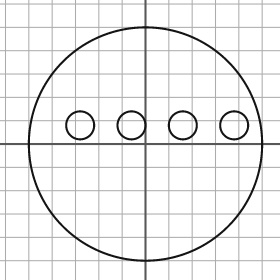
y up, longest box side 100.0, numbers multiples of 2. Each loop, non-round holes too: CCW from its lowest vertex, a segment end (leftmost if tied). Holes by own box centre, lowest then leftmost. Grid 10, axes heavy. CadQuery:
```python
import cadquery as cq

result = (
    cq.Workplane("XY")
    .moveTo(0.0, 0.0)
    .circle(50.0)
    .moveTo(-28.0, 8.0)
    .circle(6.0)
    .moveTo(-6.0, 8.0)
    .circle(6.0)
    .moveTo(16.0, 8.0)
    .circle(6.0)
    .moveTo(38.0, 8.0)
    .circle(6.0)
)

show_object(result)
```